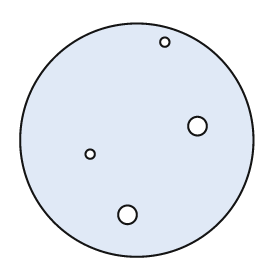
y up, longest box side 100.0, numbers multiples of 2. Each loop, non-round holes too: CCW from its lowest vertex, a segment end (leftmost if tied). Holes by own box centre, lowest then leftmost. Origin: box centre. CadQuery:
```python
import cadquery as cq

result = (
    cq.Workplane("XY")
    .moveTo(0.0, 0.0)
    .circle(50.0)
    .moveTo(-4.0, -32.0)
    .circle(4.0)
    .moveTo(-20.0, -6.0)
    .circle(2.0)
    .moveTo(26.0, 6.0)
    .circle(4.0)
    .moveTo(12.0, 42.0)
    .circle(2.0)
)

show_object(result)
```